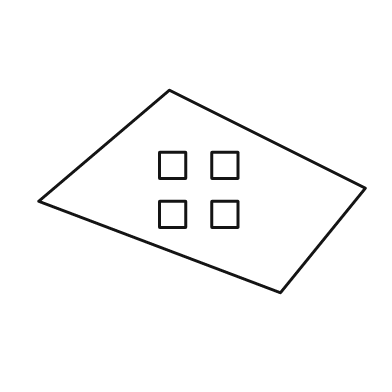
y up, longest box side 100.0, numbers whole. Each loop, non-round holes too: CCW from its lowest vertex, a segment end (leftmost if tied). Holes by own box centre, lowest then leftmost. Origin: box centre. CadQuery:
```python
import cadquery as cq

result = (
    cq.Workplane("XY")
    .moveTo(24.0, -31.0)
    .lineTo(50.0, 1.0)
    .lineTo(-10.0, 31.0)
    .lineTo(-50.0, -3.0)
    .close()
    .moveTo(-13.0, -11.0)
    .lineTo(-5.0, -11.0)
    .lineTo(-5.0, -3.0)
    .lineTo(-13.0, -3.0)
    .close()
    .moveTo(3.0, -11.0)
    .lineTo(11.0, -11.0)
    .lineTo(11.0, -3.0)
    .lineTo(3.0, -3.0)
    .close()
    .moveTo(-13.0, 4.0)
    .lineTo(-5.0, 4.0)
    .lineTo(-5.0, 12.0)
    .lineTo(-13.0, 12.0)
    .close()
    .moveTo(3.0, 4.0)
    .lineTo(11.0, 4.0)
    .lineTo(11.0, 12.0)
    .lineTo(3.0, 12.0)
    .close()
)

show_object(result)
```